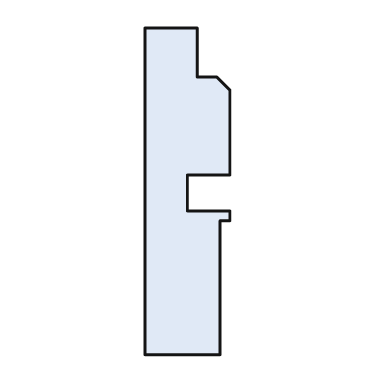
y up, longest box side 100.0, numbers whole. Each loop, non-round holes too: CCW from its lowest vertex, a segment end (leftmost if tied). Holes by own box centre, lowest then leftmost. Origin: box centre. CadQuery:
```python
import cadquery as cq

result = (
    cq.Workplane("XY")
    .moveTo(-13.0, -50.0)
    .lineTo(10.0, -50.0)
    .lineTo(10.0, -9.0)
    .lineTo(13.0, -9.0)
    .lineTo(13.0, -6.0)
    .lineTo(0.0, -6.0)
    .lineTo(0.0, 5.0)
    .lineTo(13.0, 5.0)
    .lineTo(13.0, 31.0)
    .lineTo(9.0, 35.0)
    .lineTo(3.0, 35.0)
    .lineTo(3.0, 50.0)
    .lineTo(-13.0, 50.0)
    .close()
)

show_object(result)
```